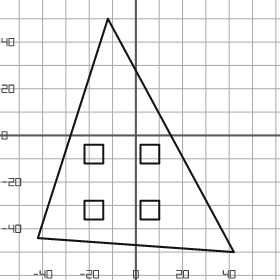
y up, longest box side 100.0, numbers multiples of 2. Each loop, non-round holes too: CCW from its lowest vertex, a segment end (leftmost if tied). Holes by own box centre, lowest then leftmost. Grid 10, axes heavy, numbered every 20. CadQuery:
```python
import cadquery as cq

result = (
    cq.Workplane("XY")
    .moveTo(42.0, -50.0)
    .lineTo(-12.0, 50.0)
    .lineTo(-42.0, -44.0)
    .close()
    .moveTo(-22.0, -36.0)
    .lineTo(-14.0, -36.0)
    .lineTo(-14.0, -28.0)
    .lineTo(-22.0, -28.0)
    .close()
    .moveTo(2.0, -36.0)
    .lineTo(10.0, -36.0)
    .lineTo(10.0, -28.0)
    .lineTo(2.0, -28.0)
    .close()
    .moveTo(-22.0, -12.0)
    .lineTo(-14.0, -12.0)
    .lineTo(-14.0, -4.0)
    .lineTo(-22.0, -4.0)
    .close()
    .moveTo(2.0, -12.0)
    .lineTo(10.0, -12.0)
    .lineTo(10.0, -4.0)
    .lineTo(2.0, -4.0)
    .close()
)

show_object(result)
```